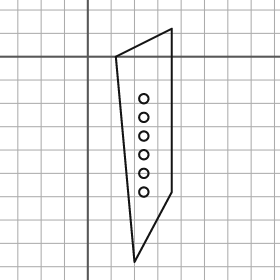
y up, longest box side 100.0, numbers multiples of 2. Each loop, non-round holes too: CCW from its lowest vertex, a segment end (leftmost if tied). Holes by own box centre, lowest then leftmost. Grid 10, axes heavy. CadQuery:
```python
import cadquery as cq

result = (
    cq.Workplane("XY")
    .moveTo(20.0, -88.0)
    .lineTo(36.0, -58.0)
    .lineTo(36.0, 12.0)
    .lineTo(12.0, 0.0)
    .close()
    .moveTo(24.0, -58.0)
    .circle(2.0)
    .moveTo(24.0, -50.0)
    .circle(2.0)
    .moveTo(24.0, -42.0)
    .circle(2.0)
    .moveTo(24.0, -34.0)
    .circle(2.0)
    .moveTo(24.0, -26.0)
    .circle(2.0)
    .moveTo(24.0, -18.0)
    .circle(2.0)
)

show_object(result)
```